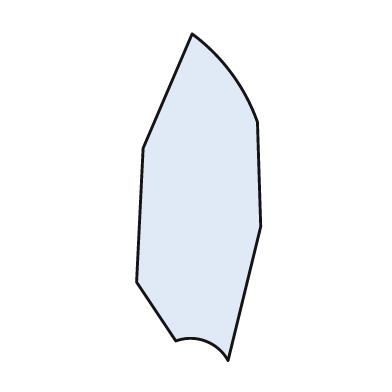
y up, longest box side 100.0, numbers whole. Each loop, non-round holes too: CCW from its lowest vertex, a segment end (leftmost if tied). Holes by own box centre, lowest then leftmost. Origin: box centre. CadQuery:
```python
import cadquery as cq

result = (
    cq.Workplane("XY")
    .moveTo(9.0, -50.0)
    .lineTo(19.0, -9.0)
    .lineTo(18.0, 23.0)
    .threePointArc((10.0, 38.0), (-2.0, 50.0))
    .lineTo(-17.0, 15.0)
    .lineTo(-19.0, -26.0)
    .lineTo(-7.0, -44.0)
    .threePointArc((2.0, -44.0), (9.0, -50.0))
    .close()
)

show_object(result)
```